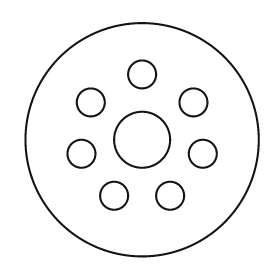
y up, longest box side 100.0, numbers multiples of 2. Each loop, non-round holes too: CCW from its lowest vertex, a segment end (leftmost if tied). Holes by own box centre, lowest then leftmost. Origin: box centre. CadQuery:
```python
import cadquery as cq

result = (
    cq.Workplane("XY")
    .moveTo(0.0, 0.0)
    .circle(50.0)
    .moveTo(-12.0, -24.0)
    .circle(6.0)
    .moveTo(12.0, -24.0)
    .circle(6.0)
    .moveTo(-26.0, -6.0)
    .circle(6.0)
    .moveTo(26.0, -6.0)
    .circle(6.0)
    .moveTo(0.0, 0.0)
    .circle(12.0)
    .moveTo(-22.0, 16.0)
    .circle(6.0)
    .moveTo(22.0, 16.0)
    .circle(6.0)
    .moveTo(0.0, 28.0)
    .circle(6.0)
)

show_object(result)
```